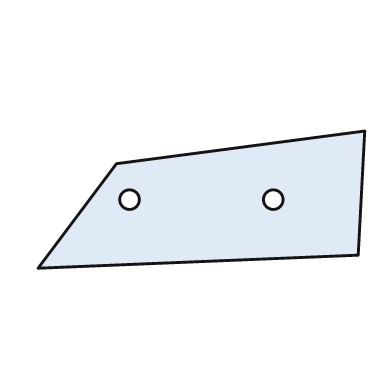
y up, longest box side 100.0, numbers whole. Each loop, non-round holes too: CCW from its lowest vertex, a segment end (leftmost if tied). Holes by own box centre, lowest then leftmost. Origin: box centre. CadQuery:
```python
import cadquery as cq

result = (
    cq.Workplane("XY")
    .moveTo(-50.0, -21.0)
    .lineTo(48.0, -17.0)
    .lineTo(50.0, 21.0)
    .lineTo(-26.0, 11.0)
    .close()
    .moveTo(-22.0, 0.0)
    .circle(3.0)
    .moveTo(22.0, 0.0)
    .circle(3.0)
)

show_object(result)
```